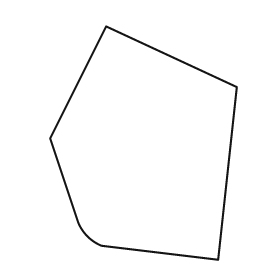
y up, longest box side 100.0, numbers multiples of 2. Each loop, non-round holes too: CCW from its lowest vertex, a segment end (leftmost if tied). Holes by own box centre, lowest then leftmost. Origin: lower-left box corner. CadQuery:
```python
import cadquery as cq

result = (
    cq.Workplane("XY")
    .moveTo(72.0, 0.0)
    .lineTo(80.0, 74.0)
    .lineTo(24.0, 100.0)
    .lineTo(0.0, 52.0)
    .lineTo(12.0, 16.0)
    .threePointArc((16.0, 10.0), (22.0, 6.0))
    .close()
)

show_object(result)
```